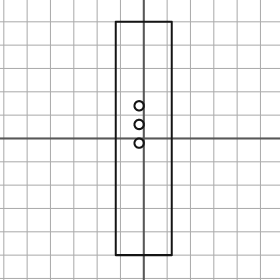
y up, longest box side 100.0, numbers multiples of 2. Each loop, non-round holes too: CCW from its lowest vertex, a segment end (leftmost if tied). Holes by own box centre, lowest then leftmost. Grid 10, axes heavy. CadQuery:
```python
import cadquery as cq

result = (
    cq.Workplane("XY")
    .moveTo(-12.0, -50.0)
    .lineTo(12.0, -50.0)
    .lineTo(12.0, 50.0)
    .lineTo(-12.0, 50.0)
    .close()
    .moveTo(-2.0, -2.0)
    .circle(2.0)
    .moveTo(-2.0, 6.0)
    .circle(2.0)
    .moveTo(-2.0, 14.0)
    .circle(2.0)
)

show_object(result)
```